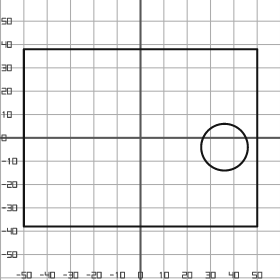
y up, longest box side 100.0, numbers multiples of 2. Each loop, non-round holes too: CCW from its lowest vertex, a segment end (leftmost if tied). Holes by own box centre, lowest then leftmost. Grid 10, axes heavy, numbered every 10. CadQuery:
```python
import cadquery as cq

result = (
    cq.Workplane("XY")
    .moveTo(-50.0, -38.0)
    .lineTo(50.0, -38.0)
    .lineTo(50.0, 38.0)
    .lineTo(-50.0, 38.0)
    .close()
    .moveTo(36.0, -4.0)
    .circle(10.0)
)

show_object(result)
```